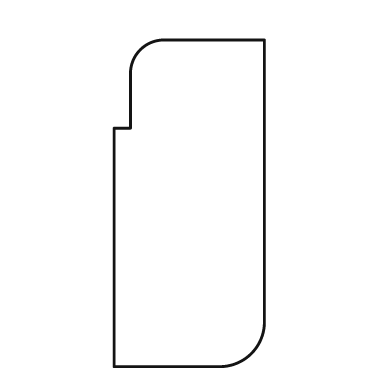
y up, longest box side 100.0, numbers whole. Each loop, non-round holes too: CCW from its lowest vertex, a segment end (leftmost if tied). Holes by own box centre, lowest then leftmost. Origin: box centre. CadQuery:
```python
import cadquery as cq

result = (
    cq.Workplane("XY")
    .moveTo(-23.0, -50.0)
    .lineTo(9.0, -50.0)
    .threePointArc((19.0, -46.0), (23.0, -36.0))
    .lineTo(23.0, 50.0)
    .lineTo(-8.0, 50.0)
    .threePointArc((-15.0, 47.0), (-18.0, 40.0))
    .lineTo(-18.0, 23.0)
    .lineTo(-23.0, 23.0)
    .close()
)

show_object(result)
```